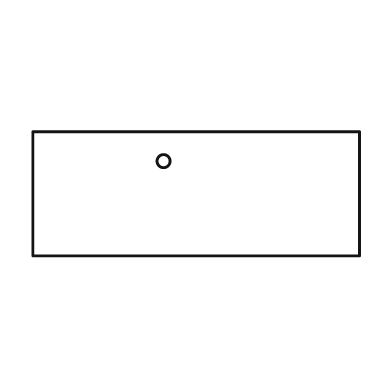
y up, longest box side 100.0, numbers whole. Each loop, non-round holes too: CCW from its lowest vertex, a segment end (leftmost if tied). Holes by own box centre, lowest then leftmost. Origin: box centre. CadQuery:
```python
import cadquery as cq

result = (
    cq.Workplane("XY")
    .moveTo(-50.0, -19.0)
    .lineTo(50.0, -19.0)
    .lineTo(50.0, 19.0)
    .lineTo(-50.0, 19.0)
    .close()
    .moveTo(-10.0, 10.0)
    .circle(2.0)
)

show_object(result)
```